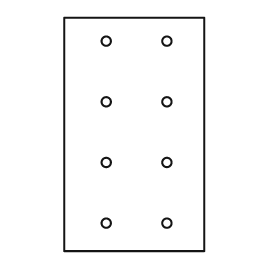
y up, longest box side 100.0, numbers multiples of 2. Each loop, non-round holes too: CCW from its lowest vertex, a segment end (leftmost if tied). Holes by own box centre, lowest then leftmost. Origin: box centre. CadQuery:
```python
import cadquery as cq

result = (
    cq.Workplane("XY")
    .moveTo(-30.0, -50.0)
    .lineTo(30.0, -50.0)
    .lineTo(30.0, 50.0)
    .lineTo(-30.0, 50.0)
    .close()
    .moveTo(-12.0, -38.0)
    .circle(2.0)
    .moveTo(14.0, -38.0)
    .circle(2.0)
    .moveTo(-12.0, -12.0)
    .circle(2.0)
    .moveTo(14.0, -12.0)
    .circle(2.0)
    .moveTo(-12.0, 14.0)
    .circle(2.0)
    .moveTo(14.0, 14.0)
    .circle(2.0)
    .moveTo(-12.0, 40.0)
    .circle(2.0)
    .moveTo(14.0, 40.0)
    .circle(2.0)
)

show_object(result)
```